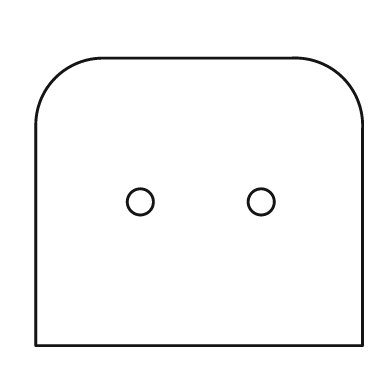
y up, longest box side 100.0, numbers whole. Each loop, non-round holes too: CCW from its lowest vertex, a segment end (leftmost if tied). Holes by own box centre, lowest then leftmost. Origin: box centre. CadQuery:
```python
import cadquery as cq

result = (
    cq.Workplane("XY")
    .moveTo(-50.0, -44.0)
    .lineTo(50.0, -44.0)
    .lineTo(50.0, 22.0)
    .threePointArc((44.0, 38.0), (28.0, 44.0))
    .lineTo(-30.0, 44.0)
    .threePointArc((-44.0, 38.0), (-50.0, 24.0))
    .close()
    .moveTo(-18.0, 0.0)
    .circle(4.0)
    .moveTo(19.0, 0.0)
    .circle(4.0)
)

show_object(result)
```